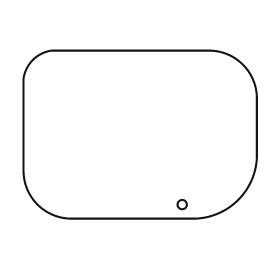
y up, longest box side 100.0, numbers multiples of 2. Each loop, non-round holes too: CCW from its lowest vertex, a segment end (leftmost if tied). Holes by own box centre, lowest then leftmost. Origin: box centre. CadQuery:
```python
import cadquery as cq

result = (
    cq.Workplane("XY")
    .moveTo(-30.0, -36.0)
    .lineTo(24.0, -36.0)
    .threePointArc((42.0, -28.0), (50.0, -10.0))
    .lineTo(50.0, 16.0)
    .threePointArc((44.0, 30.0), (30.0, 36.0))
    .lineTo(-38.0, 36.0)
    .threePointArc((-46.0, 32.0), (-50.0, 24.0))
    .lineTo(-50.0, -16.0)
    .threePointArc((-44.0, -30.0), (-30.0, -36.0))
    .close()
    .moveTo(18.0, -30.0)
    .circle(2.0)
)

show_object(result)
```